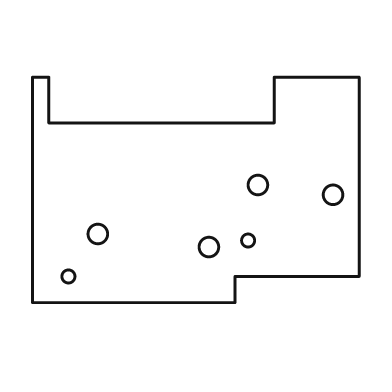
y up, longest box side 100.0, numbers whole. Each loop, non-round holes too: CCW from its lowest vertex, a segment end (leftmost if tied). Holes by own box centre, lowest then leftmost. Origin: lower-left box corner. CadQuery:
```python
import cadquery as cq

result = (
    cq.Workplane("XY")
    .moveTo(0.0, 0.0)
    .lineTo(62.0, 0.0)
    .lineTo(62.0, 8.0)
    .lineTo(100.0, 8.0)
    .lineTo(100.0, 69.0)
    .lineTo(74.0, 69.0)
    .lineTo(74.0, 55.0)
    .lineTo(5.0, 55.0)
    .lineTo(5.0, 69.0)
    .lineTo(0.0, 69.0)
    .close()
    .moveTo(11.0, 8.0)
    .circle(2.0)
    .moveTo(54.0, 17.0)
    .circle(3.0)
    .moveTo(66.0, 19.0)
    .circle(2.0)
    .moveTo(20.0, 21.0)
    .circle(3.0)
    .moveTo(92.0, 33.0)
    .circle(3.0)
    .moveTo(69.0, 36.0)
    .circle(3.0)
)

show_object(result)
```